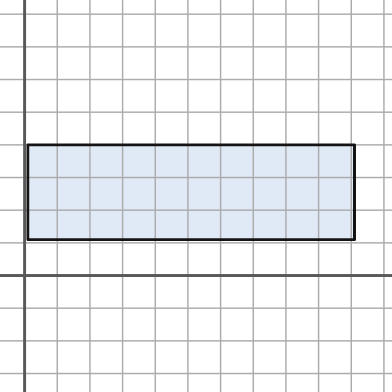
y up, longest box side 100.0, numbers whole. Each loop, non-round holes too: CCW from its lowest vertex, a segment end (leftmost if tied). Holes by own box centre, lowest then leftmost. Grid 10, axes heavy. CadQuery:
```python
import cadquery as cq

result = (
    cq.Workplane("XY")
    .moveTo(1.0, 11.0)
    .lineTo(101.0, 11.0)
    .lineTo(101.0, 40.0)
    .lineTo(1.0, 40.0)
    .close()
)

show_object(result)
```